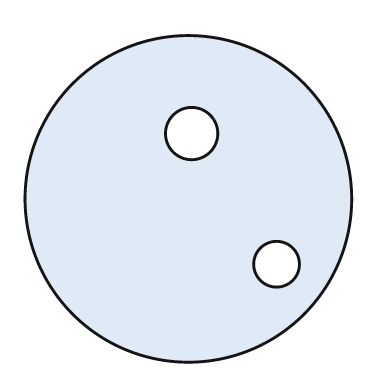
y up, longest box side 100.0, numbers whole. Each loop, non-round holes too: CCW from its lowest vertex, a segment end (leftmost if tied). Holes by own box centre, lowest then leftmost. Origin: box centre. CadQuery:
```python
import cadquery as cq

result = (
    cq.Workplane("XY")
    .moveTo(0.0, 0.0)
    .circle(50.0)
    .moveTo(27.0, -20.0)
    .circle(7.0)
    .moveTo(1.0, 20.0)
    .circle(8.0)
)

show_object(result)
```